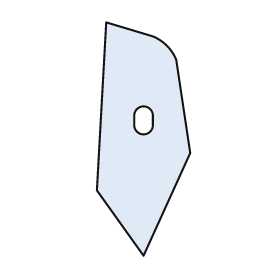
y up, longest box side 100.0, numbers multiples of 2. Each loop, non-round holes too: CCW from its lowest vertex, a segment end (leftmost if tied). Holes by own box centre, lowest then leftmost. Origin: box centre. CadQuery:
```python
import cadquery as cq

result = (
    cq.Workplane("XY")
    .moveTo(0.0, -50.0)
    .lineTo(20.0, -6.0)
    .lineTo(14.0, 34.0)
    .threePointArc((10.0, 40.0), (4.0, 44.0))
    .lineTo(-16.0, 50.0)
    .lineTo(-20.0, -22.0)
    .close()
    .moveTo(-4.0, 6.0)
    .threePointArc((0.0, 2.0), (4.0, 6.0))
    .lineTo(4.0, 10.0)
    .threePointArc((0.0, 14.0), (-4.0, 10.0))
    .close()
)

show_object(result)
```